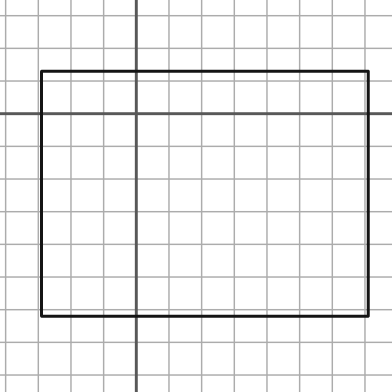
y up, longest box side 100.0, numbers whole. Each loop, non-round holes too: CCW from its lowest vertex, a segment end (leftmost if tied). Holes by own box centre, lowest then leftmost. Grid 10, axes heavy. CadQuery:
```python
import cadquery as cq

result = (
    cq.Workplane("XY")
    .moveTo(-29.0, -62.0)
    .lineTo(71.0, -62.0)
    .lineTo(71.0, 13.0)
    .lineTo(-29.0, 13.0)
    .close()
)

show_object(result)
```